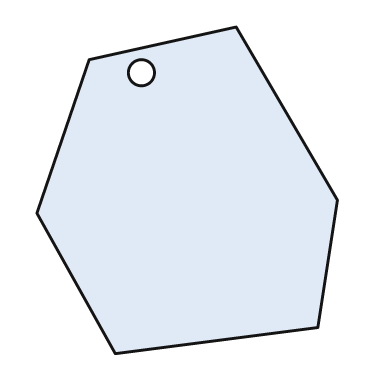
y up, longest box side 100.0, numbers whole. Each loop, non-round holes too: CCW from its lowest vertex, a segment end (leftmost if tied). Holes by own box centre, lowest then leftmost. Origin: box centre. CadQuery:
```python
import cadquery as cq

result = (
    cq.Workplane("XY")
    .moveTo(-22.0, -50.0)
    .lineTo(40.0, -42.0)
    .lineTo(46.0, -3.0)
    .lineTo(15.0, 50.0)
    .lineTo(-30.0, 40.0)
    .lineTo(-46.0, -7.0)
    .close()
    .moveTo(-14.0, 36.0)
    .circle(4.0)
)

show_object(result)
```